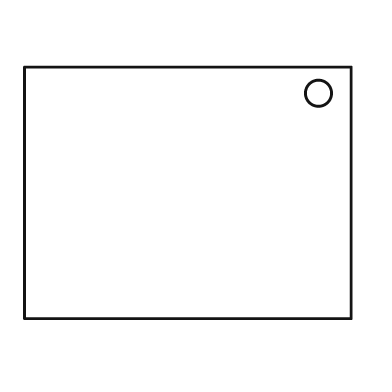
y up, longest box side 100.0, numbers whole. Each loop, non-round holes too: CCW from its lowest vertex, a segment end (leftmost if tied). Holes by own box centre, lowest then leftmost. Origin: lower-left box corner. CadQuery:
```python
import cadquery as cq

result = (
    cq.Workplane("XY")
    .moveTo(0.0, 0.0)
    .lineTo(100.0, 0.0)
    .lineTo(100.0, 77.0)
    .lineTo(0.0, 77.0)
    .close()
    .moveTo(90.0, 69.0)
    .circle(4.0)
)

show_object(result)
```